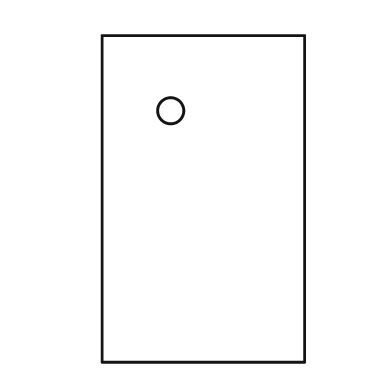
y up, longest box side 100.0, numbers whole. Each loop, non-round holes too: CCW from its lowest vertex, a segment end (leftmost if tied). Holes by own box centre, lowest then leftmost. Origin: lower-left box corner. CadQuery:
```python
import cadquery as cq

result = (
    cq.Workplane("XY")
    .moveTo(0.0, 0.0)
    .lineTo(62.0, 0.0)
    .lineTo(62.0, 100.0)
    .lineTo(0.0, 100.0)
    .close()
    .moveTo(21.0, 77.0)
    .circle(4.0)
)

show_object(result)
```